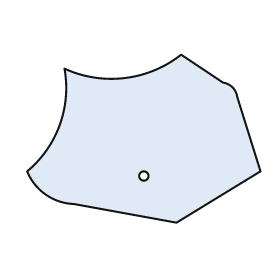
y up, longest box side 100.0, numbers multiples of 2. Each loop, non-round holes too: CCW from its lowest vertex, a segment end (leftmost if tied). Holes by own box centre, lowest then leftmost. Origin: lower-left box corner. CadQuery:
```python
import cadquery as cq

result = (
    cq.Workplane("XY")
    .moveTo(64.0, 0.0)
    .lineTo(100.0, 22.0)
    .lineTo(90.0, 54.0)
    .threePointArc((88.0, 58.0), (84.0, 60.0))
    .lineTo(66.0, 72.0)
    .threePointArc((42.0, 62.0), (16.0, 66.0))
    .threePointArc((14.0, 42.0), (0.0, 22.0))
    .threePointArc((8.0, 12.0), (20.0, 8.0))
    .close()
    .moveTo(50.0, 20.0)
    .circle(2.0)
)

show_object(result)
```